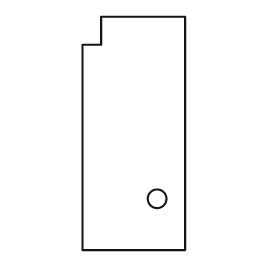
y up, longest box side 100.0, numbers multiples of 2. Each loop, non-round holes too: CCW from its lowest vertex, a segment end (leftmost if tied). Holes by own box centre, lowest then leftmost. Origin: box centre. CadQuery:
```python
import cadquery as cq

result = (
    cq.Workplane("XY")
    .moveTo(-22.0, -50.0)
    .lineTo(22.0, -50.0)
    .lineTo(22.0, 50.0)
    .lineTo(-14.0, 50.0)
    .lineTo(-14.0, 38.0)
    .lineTo(-22.0, 38.0)
    .close()
    .moveTo(10.0, -28.0)
    .circle(4.0)
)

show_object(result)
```